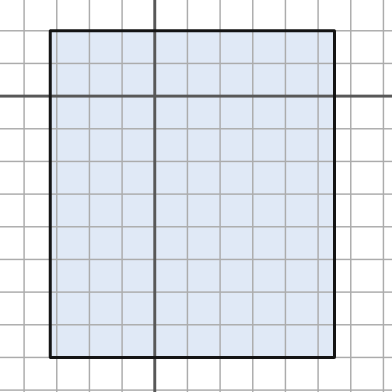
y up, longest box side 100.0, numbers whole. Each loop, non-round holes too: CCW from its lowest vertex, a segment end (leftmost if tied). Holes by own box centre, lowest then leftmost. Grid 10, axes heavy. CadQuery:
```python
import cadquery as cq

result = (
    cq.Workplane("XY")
    .moveTo(-32.0, -80.0)
    .lineTo(55.0, -80.0)
    .lineTo(55.0, 20.0)
    .lineTo(-32.0, 20.0)
    .close()
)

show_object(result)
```